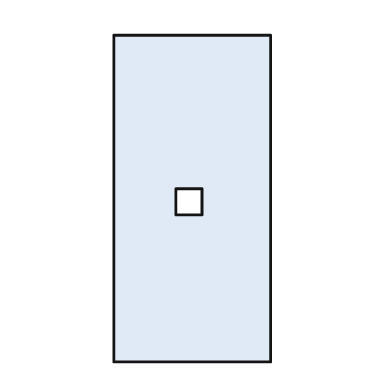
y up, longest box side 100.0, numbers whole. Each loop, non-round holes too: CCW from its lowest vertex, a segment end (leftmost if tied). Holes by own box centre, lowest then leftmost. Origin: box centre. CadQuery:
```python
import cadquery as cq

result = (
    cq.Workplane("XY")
    .moveTo(-24.0, -50.0)
    .lineTo(24.0, -50.0)
    .lineTo(24.0, 50.0)
    .lineTo(-24.0, 50.0)
    .close()
    .moveTo(-5.0, -5.0)
    .lineTo(3.0, -5.0)
    .lineTo(3.0, 3.0)
    .lineTo(-5.0, 3.0)
    .close()
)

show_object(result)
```